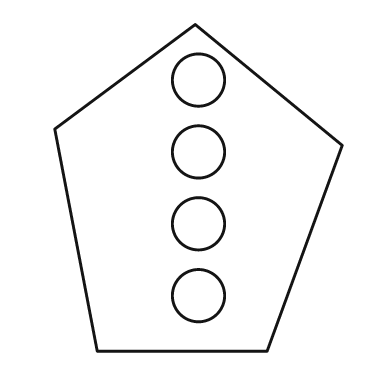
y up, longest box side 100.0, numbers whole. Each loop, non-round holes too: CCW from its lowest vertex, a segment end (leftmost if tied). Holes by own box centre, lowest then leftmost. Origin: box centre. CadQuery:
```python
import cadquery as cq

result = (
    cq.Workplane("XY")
    .moveTo(-31.0, -50.0)
    .lineTo(21.0, -50.0)
    .lineTo(44.0, 13.0)
    .lineTo(-1.0, 50.0)
    .lineTo(-44.0, 18.0)
    .close()
    .moveTo(0.0, -33.0)
    .circle(8.0)
    .moveTo(0.0, -11.0)
    .circle(8.0)
    .moveTo(0.0, 11.0)
    .circle(8.0)
    .moveTo(0.0, 33.0)
    .circle(8.0)
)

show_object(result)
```